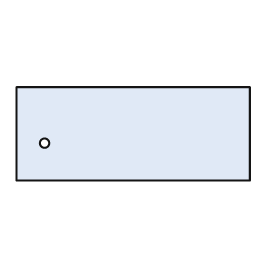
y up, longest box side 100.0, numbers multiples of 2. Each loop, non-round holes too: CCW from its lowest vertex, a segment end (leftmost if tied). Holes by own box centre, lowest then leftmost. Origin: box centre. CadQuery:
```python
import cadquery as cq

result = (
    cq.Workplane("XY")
    .moveTo(-50.0, -20.0)
    .lineTo(50.0, -20.0)
    .lineTo(50.0, 20.0)
    .lineTo(-50.0, 20.0)
    .close()
    .moveTo(-38.0, -4.0)
    .circle(2.0)
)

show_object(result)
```